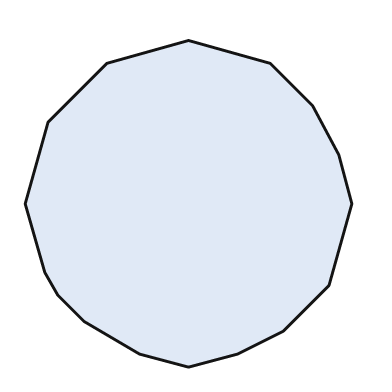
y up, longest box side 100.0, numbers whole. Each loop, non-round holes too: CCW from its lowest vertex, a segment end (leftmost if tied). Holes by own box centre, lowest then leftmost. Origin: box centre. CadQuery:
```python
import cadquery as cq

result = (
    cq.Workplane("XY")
    .moveTo(0.0, -50.0)
    .lineTo(15.0, -46.0)
    .lineTo(29.0, -39.0)
    .lineTo(43.0, -25.0)
    .lineTo(50.0, 0.0)
    .lineTo(46.0, 15.0)
    .lineTo(38.0, 30.0)
    .lineTo(25.0, 43.0)
    .lineTo(0.0, 50.0)
    .lineTo(-25.0, 43.0)
    .lineTo(-43.0, 25.0)
    .lineTo(-50.0, 0.0)
    .lineTo(-44.0, -21.0)
    .lineTo(-40.0, -28.0)
    .lineTo(-32.0, -36.0)
    .lineTo(-15.0, -46.0)
    .close()
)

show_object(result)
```